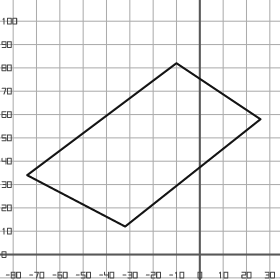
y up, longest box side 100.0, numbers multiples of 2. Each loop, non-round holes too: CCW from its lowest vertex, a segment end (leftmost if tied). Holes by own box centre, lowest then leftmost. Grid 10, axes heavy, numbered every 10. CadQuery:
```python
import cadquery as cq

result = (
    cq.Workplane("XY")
    .moveTo(-32.0, 12.0)
    .lineTo(26.0, 58.0)
    .lineTo(-10.0, 82.0)
    .lineTo(-74.0, 34.0)
    .close()
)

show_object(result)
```